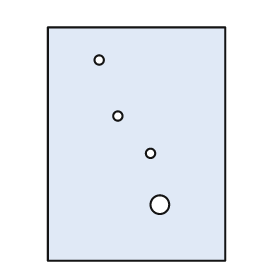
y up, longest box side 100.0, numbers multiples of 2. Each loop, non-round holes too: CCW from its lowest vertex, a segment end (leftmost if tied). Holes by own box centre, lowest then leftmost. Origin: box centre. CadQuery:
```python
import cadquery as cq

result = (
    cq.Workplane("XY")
    .moveTo(-38.0, -50.0)
    .lineTo(38.0, -50.0)
    .lineTo(38.0, 50.0)
    .lineTo(-38.0, 50.0)
    .close()
    .moveTo(10.0, -26.0)
    .circle(4.0)
    .moveTo(6.0, -4.0)
    .circle(2.0)
    .moveTo(-8.0, 12.0)
    .circle(2.0)
    .moveTo(-16.0, 36.0)
    .circle(2.0)
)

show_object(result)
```